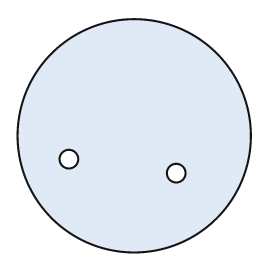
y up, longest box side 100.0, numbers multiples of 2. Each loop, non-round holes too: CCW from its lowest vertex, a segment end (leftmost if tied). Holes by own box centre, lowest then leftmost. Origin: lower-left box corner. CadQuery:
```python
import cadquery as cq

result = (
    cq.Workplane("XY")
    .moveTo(50.0, 50.0)
    .circle(50.0)
    .moveTo(68.0, 34.0)
    .circle(4.0)
    .moveTo(22.0, 40.0)
    .circle(4.0)
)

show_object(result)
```